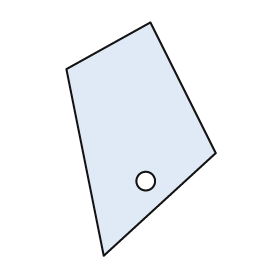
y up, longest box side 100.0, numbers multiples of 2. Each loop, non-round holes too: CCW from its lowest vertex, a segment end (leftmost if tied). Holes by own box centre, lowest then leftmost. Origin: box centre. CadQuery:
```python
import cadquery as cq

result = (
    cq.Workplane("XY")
    .moveTo(-16.0, -50.0)
    .lineTo(32.0, -6.0)
    .lineTo(4.0, 50.0)
    .lineTo(-32.0, 30.0)
    .close()
    .moveTo(2.0, -18.0)
    .circle(4.0)
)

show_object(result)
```